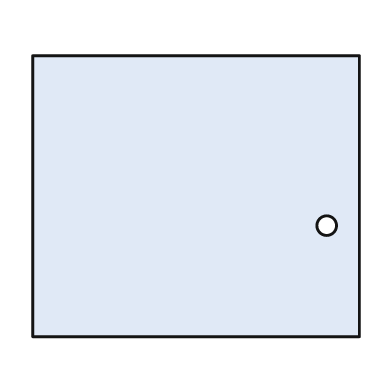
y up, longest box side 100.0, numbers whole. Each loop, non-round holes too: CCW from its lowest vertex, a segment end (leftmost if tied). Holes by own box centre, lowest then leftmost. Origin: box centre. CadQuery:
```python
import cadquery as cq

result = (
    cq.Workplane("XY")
    .moveTo(-50.0, -43.0)
    .lineTo(50.0, -43.0)
    .lineTo(50.0, 43.0)
    .lineTo(-50.0, 43.0)
    .close()
    .moveTo(40.0, -9.0)
    .circle(3.0)
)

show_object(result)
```